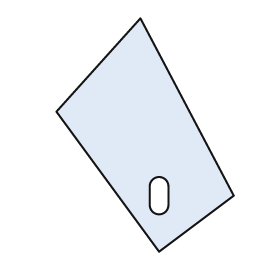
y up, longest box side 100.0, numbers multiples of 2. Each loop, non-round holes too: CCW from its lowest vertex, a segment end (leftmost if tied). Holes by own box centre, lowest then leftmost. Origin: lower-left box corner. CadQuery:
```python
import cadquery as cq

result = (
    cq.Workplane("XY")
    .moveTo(44.0, 0.0)
    .lineTo(76.0, 24.0)
    .lineTo(36.0, 100.0)
    .lineTo(0.0, 60.0)
    .close()
    .moveTo(40.0, 20.0)
    .threePointArc((44.0, 16.0), (48.0, 20.0))
    .lineTo(48.0, 28.0)
    .threePointArc((44.0, 32.0), (40.0, 28.0))
    .close()
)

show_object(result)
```